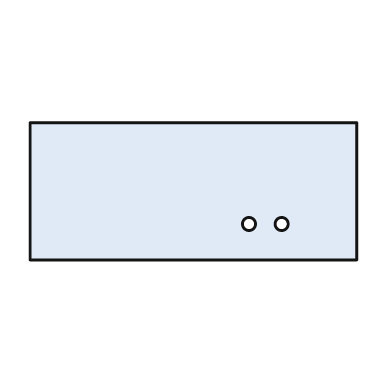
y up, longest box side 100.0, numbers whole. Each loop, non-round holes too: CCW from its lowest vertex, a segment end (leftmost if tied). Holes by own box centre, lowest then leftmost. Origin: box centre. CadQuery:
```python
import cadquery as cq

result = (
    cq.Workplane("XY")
    .moveTo(-50.0, -21.0)
    .lineTo(50.0, -21.0)
    .lineTo(50.0, 21.0)
    .lineTo(-50.0, 21.0)
    .close()
    .moveTo(17.0, -10.0)
    .circle(2.0)
    .moveTo(27.0, -10.0)
    .circle(2.0)
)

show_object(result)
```